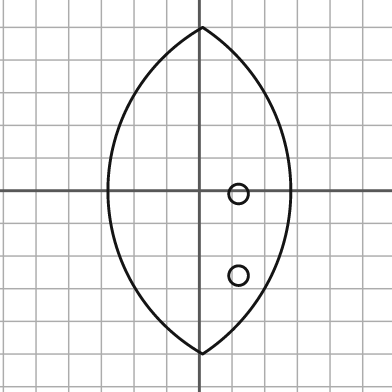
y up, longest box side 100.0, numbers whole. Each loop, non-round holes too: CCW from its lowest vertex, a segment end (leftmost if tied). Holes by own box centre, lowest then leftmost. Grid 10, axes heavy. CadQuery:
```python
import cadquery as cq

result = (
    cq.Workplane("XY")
    .moveTo(1.0, -50.0)
    .threePointArc((28.0, 0.0), (1.0, 50.0))
    .threePointArc((-28.0, 0.0), (1.0, -50.0))
    .close()
    .moveTo(12.0, -26.0)
    .circle(3.0)
    .moveTo(12.0, -1.0)
    .circle(3.0)
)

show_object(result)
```